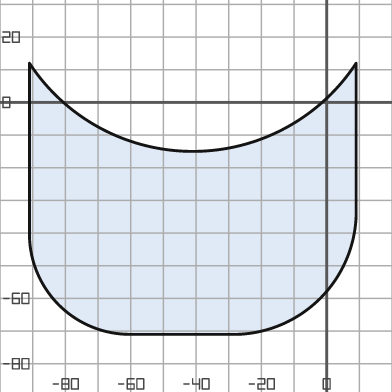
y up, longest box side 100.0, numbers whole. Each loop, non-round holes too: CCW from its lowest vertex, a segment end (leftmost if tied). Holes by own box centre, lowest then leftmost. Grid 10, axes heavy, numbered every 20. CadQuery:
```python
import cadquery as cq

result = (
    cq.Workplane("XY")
    .moveTo(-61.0, -71.0)
    .lineTo(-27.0, -71.0)
    .threePointArc((-2.0, -60.0), (9.0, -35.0))
    .lineTo(9.0, 12.0)
    .threePointArc((-41.0, -15.0), (-91.0, 12.0))
    .lineTo(-91.0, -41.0)
    .threePointArc((-82.0, -62.0), (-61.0, -71.0))
    .close()
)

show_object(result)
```